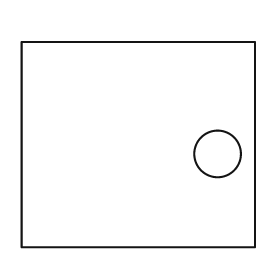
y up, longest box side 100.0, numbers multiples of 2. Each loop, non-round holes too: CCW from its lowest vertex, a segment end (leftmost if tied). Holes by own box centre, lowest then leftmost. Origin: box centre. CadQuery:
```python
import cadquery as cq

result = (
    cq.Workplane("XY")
    .moveTo(-50.0, -44.0)
    .lineTo(50.0, -44.0)
    .lineTo(50.0, 44.0)
    .lineTo(-50.0, 44.0)
    .close()
    .moveTo(34.0, -4.0)
    .circle(10.0)
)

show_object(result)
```